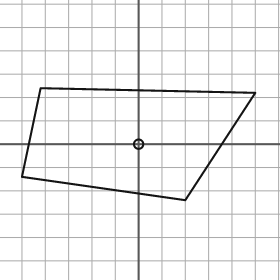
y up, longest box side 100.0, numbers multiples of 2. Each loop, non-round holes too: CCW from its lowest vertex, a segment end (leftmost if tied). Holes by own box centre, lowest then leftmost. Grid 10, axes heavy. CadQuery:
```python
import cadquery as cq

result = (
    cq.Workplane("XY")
    .moveTo(20.0, -24.0)
    .lineTo(50.0, 22.0)
    .lineTo(-42.0, 24.0)
    .lineTo(-50.0, -14.0)
    .close()
    .moveTo(0.0, 0.0)
    .circle(2.0)
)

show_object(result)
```